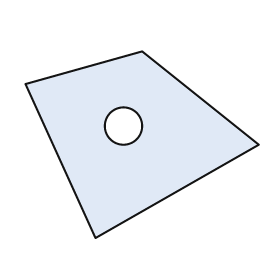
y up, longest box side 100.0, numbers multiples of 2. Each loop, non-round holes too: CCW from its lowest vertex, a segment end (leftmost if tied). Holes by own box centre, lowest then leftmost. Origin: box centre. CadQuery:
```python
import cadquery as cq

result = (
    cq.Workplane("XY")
    .moveTo(-20.0, -40.0)
    .lineTo(50.0, 0.0)
    .lineTo(0.0, 40.0)
    .lineTo(-50.0, 26.0)
    .close()
    .moveTo(-8.0, 8.0)
    .circle(8.0)
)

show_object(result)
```